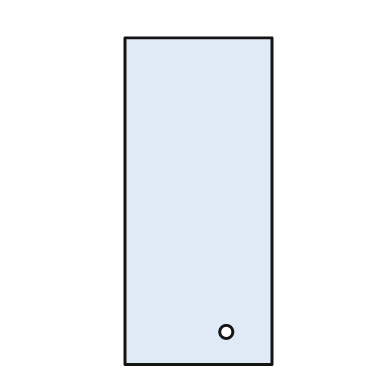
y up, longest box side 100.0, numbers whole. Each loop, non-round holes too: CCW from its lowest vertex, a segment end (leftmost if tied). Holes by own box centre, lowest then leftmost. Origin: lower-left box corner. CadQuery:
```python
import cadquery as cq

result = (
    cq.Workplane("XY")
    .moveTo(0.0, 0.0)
    .lineTo(45.0, 0.0)
    .lineTo(45.0, 100.0)
    .lineTo(0.0, 100.0)
    .close()
    .moveTo(31.0, 10.0)
    .circle(2.0)
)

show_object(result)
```